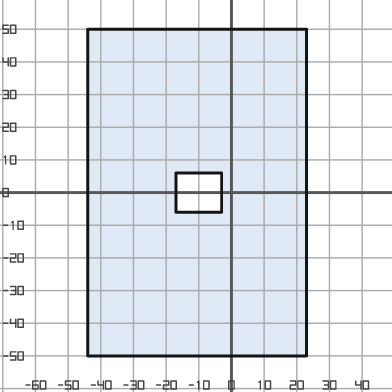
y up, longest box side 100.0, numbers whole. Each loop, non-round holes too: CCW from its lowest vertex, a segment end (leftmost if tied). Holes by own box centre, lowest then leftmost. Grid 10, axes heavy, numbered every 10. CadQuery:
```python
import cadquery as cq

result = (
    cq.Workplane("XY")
    .moveTo(-44.0, -50.0)
    .lineTo(23.0, -50.0)
    .lineTo(23.0, 50.0)
    .lineTo(-44.0, 50.0)
    .close()
    .moveTo(-17.0, -6.0)
    .lineTo(-3.0, -6.0)
    .lineTo(-3.0, 6.0)
    .lineTo(-17.0, 6.0)
    .close()
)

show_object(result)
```